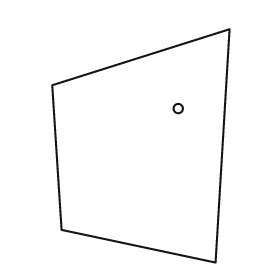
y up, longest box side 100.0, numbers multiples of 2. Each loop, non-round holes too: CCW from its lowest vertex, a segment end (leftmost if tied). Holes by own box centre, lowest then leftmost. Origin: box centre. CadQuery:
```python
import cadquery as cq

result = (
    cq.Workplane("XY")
    .moveTo(32.0, -50.0)
    .lineTo(38.0, 50.0)
    .lineTo(-38.0, 26.0)
    .lineTo(-34.0, -36.0)
    .close()
    .moveTo(16.0, 16.0)
    .circle(2.0)
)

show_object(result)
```